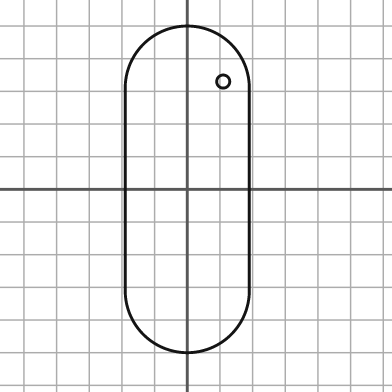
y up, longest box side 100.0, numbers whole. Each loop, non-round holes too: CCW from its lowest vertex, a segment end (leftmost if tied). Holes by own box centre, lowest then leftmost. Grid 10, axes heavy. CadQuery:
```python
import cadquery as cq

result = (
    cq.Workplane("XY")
    .moveTo(-19.0, -31.0)
    .threePointArc((0.0, -50.0), (19.0, -31.0))
    .lineTo(19.0, 31.0)
    .threePointArc((0.0, 50.0), (-19.0, 31.0))
    .close()
    .moveTo(11.0, 33.0)
    .circle(2.0)
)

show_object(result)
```